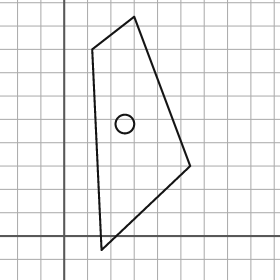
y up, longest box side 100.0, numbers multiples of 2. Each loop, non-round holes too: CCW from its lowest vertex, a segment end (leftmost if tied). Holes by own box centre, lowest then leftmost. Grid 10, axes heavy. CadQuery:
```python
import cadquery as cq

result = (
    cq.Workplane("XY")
    .moveTo(16.0, -6.0)
    .lineTo(54.0, 30.0)
    .lineTo(30.0, 94.0)
    .lineTo(12.0, 80.0)
    .close()
    .moveTo(26.0, 48.0)
    .circle(4.0)
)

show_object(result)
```